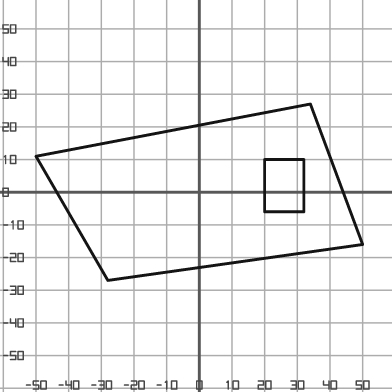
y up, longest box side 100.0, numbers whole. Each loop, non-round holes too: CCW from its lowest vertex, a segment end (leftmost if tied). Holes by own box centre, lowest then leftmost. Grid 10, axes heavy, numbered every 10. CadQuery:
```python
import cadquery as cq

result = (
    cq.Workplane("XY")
    .moveTo(-28.0, -27.0)
    .lineTo(50.0, -16.0)
    .lineTo(34.0, 27.0)
    .lineTo(-50.0, 11.0)
    .close()
    .moveTo(20.0, -6.0)
    .lineTo(32.0, -6.0)
    .lineTo(32.0, 10.0)
    .lineTo(20.0, 10.0)
    .close()
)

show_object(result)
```